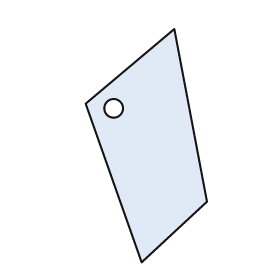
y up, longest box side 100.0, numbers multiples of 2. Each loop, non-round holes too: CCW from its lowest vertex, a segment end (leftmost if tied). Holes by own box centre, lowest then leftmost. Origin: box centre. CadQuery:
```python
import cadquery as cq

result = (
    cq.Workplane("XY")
    .moveTo(-2.0, -50.0)
    .lineTo(26.0, -24.0)
    .lineTo(12.0, 50.0)
    .lineTo(-26.0, 18.0)
    .close()
    .moveTo(-14.0, 16.0)
    .circle(4.0)
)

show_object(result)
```